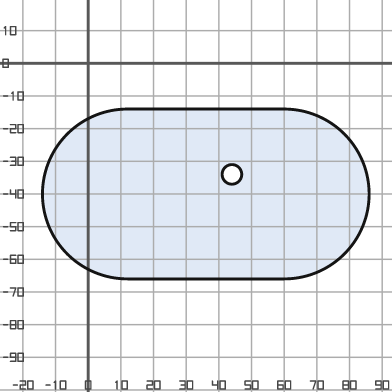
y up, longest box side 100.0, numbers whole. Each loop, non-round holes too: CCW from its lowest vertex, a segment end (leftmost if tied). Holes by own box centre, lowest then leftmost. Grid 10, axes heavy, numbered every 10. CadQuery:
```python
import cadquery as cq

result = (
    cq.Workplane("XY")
    .moveTo(12.0, -66.0)
    .lineTo(60.0, -66.0)
    .threePointArc((86.0, -40.0), (60.0, -14.0))
    .lineTo(12.0, -14.0)
    .threePointArc((-14.0, -40.0), (12.0, -66.0))
    .close()
    .moveTo(44.0, -34.0)
    .circle(3.0)
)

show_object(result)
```